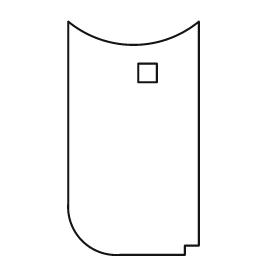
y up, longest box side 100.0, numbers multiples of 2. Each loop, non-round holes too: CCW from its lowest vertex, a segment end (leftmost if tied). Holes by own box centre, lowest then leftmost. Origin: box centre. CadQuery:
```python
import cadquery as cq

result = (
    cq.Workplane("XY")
    .moveTo(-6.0, -50.0)
    .lineTo(22.0, -50.0)
    .lineTo(22.0, -46.0)
    .lineTo(28.0, -46.0)
    .lineTo(28.0, 50.0)
    .threePointArc((0.0, 40.0), (-28.0, 50.0))
    .lineTo(-28.0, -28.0)
    .threePointArc((-22.0, -44.0), (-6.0, -50.0))
    .close()
    .moveTo(2.0, 24.0)
    .lineTo(10.0, 24.0)
    .lineTo(10.0, 32.0)
    .lineTo(2.0, 32.0)
    .close()
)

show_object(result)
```